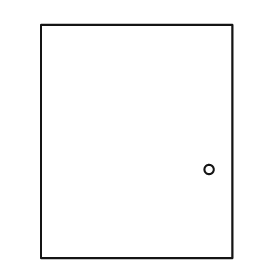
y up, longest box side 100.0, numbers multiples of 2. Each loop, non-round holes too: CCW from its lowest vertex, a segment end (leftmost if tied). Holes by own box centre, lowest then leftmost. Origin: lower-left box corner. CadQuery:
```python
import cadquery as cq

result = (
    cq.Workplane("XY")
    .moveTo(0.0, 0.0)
    .lineTo(82.0, 0.0)
    .lineTo(82.0, 100.0)
    .lineTo(0.0, 100.0)
    .close()
    .moveTo(72.0, 38.0)
    .circle(2.0)
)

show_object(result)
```